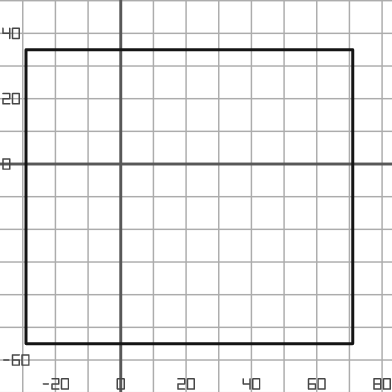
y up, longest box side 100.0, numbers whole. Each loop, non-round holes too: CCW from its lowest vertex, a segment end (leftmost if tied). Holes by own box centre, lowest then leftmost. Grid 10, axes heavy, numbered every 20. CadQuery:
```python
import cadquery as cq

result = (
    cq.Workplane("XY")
    .moveTo(-29.0, -55.0)
    .lineTo(71.0, -55.0)
    .lineTo(71.0, 35.0)
    .lineTo(-29.0, 35.0)
    .close()
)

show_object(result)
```